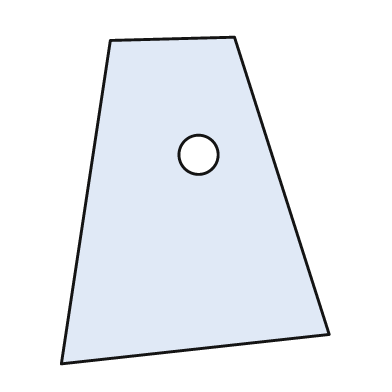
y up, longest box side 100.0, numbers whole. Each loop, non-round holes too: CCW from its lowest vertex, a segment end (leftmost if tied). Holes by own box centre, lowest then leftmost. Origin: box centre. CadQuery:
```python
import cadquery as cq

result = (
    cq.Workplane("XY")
    .moveTo(-41.0, -50.0)
    .lineTo(41.0, -41.0)
    .lineTo(12.0, 50.0)
    .lineTo(-26.0, 49.0)
    .close()
    .moveTo(1.0, 14.0)
    .circle(6.0)
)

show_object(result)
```